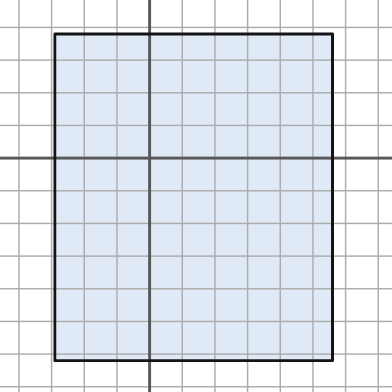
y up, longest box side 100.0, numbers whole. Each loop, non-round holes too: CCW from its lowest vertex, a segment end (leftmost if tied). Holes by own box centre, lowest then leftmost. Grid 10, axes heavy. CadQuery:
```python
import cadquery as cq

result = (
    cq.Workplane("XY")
    .moveTo(-29.0, -62.0)
    .lineTo(56.0, -62.0)
    .lineTo(56.0, 38.0)
    .lineTo(-29.0, 38.0)
    .close()
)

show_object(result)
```